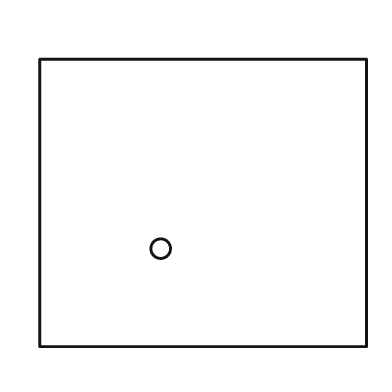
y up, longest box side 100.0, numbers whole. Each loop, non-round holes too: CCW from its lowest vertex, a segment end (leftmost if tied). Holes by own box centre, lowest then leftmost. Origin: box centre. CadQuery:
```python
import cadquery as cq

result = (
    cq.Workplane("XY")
    .moveTo(-50.0, -44.0)
    .lineTo(50.0, -44.0)
    .lineTo(50.0, 44.0)
    .lineTo(-50.0, 44.0)
    .close()
    .moveTo(-13.0, -14.0)
    .circle(3.0)
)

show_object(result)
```